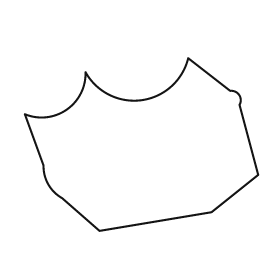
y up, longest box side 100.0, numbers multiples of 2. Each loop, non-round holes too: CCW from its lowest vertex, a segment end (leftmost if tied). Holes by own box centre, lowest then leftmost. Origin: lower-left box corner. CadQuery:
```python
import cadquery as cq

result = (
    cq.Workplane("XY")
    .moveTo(32.0, 0.0)
    .lineTo(80.0, 8.0)
    .lineTo(100.0, 24.0)
    .lineTo(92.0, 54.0)
    .threePointArc((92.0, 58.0), (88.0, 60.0))
    .lineTo(70.0, 74.0)
    .threePointArc((50.0, 56.0), (26.0, 68.0))
    .threePointArc((18.0, 52.0), (0.0, 50.0))
    .lineTo(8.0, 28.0)
    .threePointArc((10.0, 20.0), (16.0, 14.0))
    .close()
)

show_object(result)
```